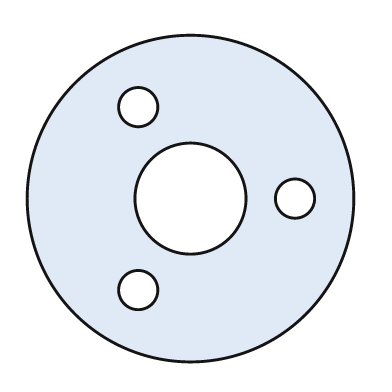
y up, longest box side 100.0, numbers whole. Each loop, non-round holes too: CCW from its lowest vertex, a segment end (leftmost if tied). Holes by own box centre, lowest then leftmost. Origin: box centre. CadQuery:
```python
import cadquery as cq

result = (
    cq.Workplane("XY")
    .moveTo(0.0, 0.0)
    .circle(50.0)
    .moveTo(-16.0, -28.0)
    .circle(6.0)
    .moveTo(0.0, 0.0)
    .circle(17.0)
    .moveTo(32.0, 0.0)
    .circle(6.0)
    .moveTo(-16.0, 28.0)
    .circle(6.0)
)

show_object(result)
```